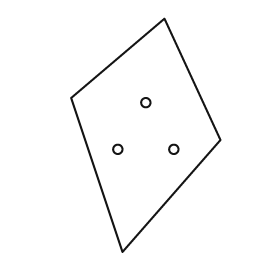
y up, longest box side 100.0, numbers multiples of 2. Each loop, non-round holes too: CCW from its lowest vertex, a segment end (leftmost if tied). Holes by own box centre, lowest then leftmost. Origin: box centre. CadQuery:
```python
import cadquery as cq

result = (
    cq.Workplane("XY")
    .moveTo(-10.0, -50.0)
    .lineTo(32.0, -2.0)
    .lineTo(8.0, 50.0)
    .lineTo(-32.0, 16.0)
    .close()
    .moveTo(-12.0, -6.0)
    .circle(2.0)
    .moveTo(12.0, -6.0)
    .circle(2.0)
    .moveTo(0.0, 14.0)
    .circle(2.0)
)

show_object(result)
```